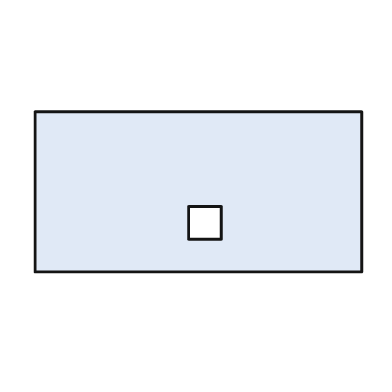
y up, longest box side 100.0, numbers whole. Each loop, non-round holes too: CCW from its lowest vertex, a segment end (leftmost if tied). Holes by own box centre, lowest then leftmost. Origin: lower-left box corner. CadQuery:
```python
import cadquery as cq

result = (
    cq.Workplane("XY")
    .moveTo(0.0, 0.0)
    .lineTo(100.0, 0.0)
    .lineTo(100.0, 49.0)
    .lineTo(0.0, 49.0)
    .close()
    .moveTo(47.0, 10.0)
    .lineTo(57.0, 10.0)
    .lineTo(57.0, 20.0)
    .lineTo(47.0, 20.0)
    .close()
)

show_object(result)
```